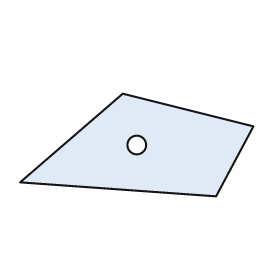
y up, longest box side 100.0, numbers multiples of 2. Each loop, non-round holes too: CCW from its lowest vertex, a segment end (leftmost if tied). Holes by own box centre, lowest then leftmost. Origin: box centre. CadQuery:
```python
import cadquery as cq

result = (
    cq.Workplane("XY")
    .moveTo(34.0, -22.0)
    .lineTo(50.0, 8.0)
    .lineTo(-6.0, 22.0)
    .lineTo(-50.0, -16.0)
    .close()
    .moveTo(0.0, 0.0)
    .circle(4.0)
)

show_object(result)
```